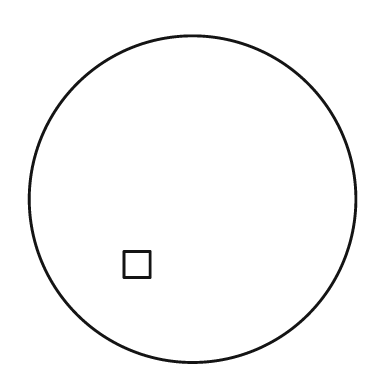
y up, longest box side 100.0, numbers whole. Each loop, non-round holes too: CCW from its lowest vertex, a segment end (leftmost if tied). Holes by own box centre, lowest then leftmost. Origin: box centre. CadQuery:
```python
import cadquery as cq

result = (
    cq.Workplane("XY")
    .moveTo(0.0, 0.0)
    .circle(50.0)
    .moveTo(-21.0, -24.0)
    .lineTo(-13.0, -24.0)
    .lineTo(-13.0, -16.0)
    .lineTo(-21.0, -16.0)
    .close()
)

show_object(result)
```